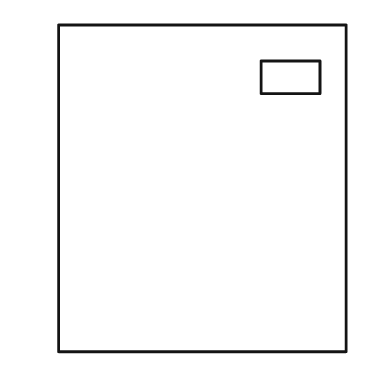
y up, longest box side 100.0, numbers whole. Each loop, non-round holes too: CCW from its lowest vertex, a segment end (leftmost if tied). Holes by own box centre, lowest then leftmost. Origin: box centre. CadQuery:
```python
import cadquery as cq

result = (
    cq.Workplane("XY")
    .moveTo(-44.0, -50.0)
    .lineTo(44.0, -50.0)
    .lineTo(44.0, 50.0)
    .lineTo(-44.0, 50.0)
    .close()
    .moveTo(18.0, 29.0)
    .lineTo(36.0, 29.0)
    .lineTo(36.0, 39.0)
    .lineTo(18.0, 39.0)
    .close()
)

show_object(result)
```